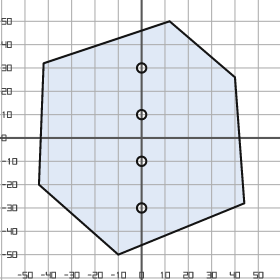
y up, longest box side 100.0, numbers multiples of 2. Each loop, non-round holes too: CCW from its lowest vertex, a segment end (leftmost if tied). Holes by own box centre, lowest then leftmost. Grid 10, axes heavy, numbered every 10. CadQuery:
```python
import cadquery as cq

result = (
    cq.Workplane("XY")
    .moveTo(-10.0, -50.0)
    .lineTo(44.0, -28.0)
    .lineTo(40.0, 26.0)
    .lineTo(12.0, 50.0)
    .lineTo(-42.0, 32.0)
    .lineTo(-44.0, -20.0)
    .close()
    .moveTo(0.0, -30.0)
    .circle(2.0)
    .moveTo(0.0, -10.0)
    .circle(2.0)
    .moveTo(0.0, 10.0)
    .circle(2.0)
    .moveTo(0.0, 30.0)
    .circle(2.0)
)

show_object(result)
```